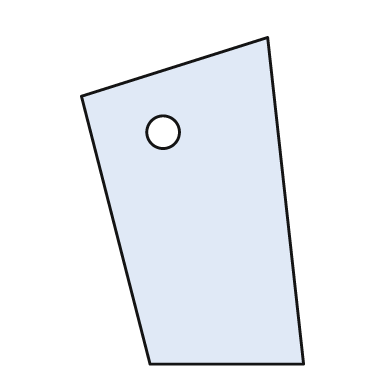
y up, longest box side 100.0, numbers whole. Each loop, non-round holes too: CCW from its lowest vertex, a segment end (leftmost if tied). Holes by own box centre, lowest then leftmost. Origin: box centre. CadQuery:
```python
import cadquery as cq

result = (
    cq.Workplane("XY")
    .moveTo(-13.0, -50.0)
    .lineTo(34.0, -50.0)
    .lineTo(23.0, 50.0)
    .lineTo(-34.0, 32.0)
    .close()
    .moveTo(-9.0, 21.0)
    .circle(5.0)
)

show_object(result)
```